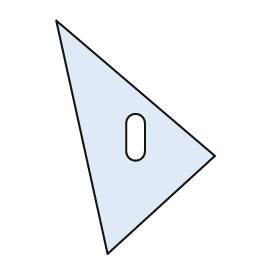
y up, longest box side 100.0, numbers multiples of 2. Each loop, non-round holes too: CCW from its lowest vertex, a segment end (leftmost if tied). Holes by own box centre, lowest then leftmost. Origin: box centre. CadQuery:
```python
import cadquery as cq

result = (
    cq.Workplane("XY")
    .moveTo(-12.0, -50.0)
    .lineTo(34.0, -8.0)
    .lineTo(-34.0, 50.0)
    .close()
    .moveTo(-4.0, -6.0)
    .threePointArc((0.0, -10.0), (4.0, -6.0))
    .lineTo(4.0, 6.0)
    .threePointArc((0.0, 10.0), (-4.0, 6.0))
    .close()
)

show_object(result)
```